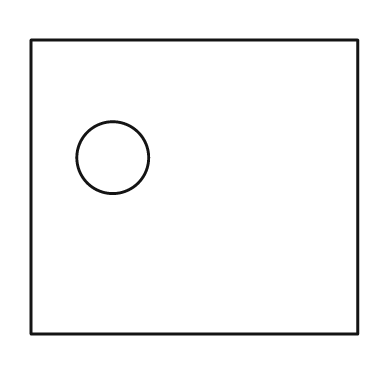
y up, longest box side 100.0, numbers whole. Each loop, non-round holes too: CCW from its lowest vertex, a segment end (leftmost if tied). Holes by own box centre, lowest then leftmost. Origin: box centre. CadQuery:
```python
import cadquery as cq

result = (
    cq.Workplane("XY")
    .moveTo(-50.0, -45.0)
    .lineTo(50.0, -45.0)
    .lineTo(50.0, 45.0)
    .lineTo(-50.0, 45.0)
    .close()
    .moveTo(-25.0, 9.0)
    .circle(11.0)
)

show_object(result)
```